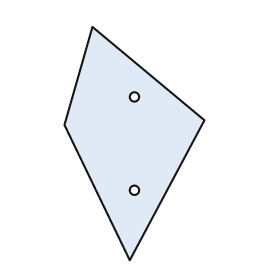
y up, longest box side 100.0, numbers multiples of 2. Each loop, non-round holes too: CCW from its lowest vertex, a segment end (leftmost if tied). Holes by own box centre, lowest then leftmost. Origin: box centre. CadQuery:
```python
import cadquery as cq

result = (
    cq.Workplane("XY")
    .moveTo(-2.0, -50.0)
    .lineTo(30.0, 10.0)
    .lineTo(-18.0, 50.0)
    .lineTo(-30.0, 8.0)
    .close()
    .moveTo(0.0, -20.0)
    .circle(2.0)
    .moveTo(0.0, 20.0)
    .circle(2.0)
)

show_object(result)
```